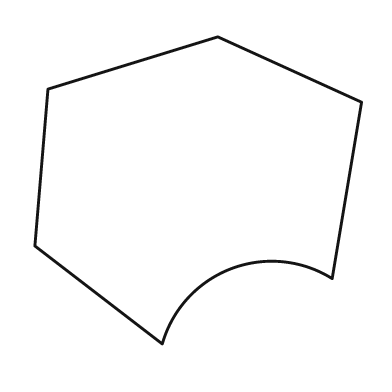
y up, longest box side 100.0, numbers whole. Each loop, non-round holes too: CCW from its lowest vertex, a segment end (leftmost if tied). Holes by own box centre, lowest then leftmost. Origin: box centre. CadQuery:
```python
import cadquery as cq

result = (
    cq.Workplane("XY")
    .moveTo(-11.0, -47.0)
    .threePointArc((10.0, -24.0), (41.0, -27.0))
    .lineTo(50.0, 27.0)
    .lineTo(6.0, 47.0)
    .lineTo(-46.0, 31.0)
    .lineTo(-50.0, -17.0)
    .close()
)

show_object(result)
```